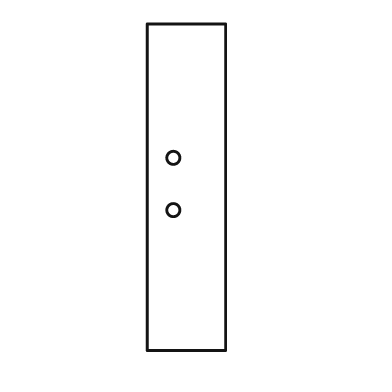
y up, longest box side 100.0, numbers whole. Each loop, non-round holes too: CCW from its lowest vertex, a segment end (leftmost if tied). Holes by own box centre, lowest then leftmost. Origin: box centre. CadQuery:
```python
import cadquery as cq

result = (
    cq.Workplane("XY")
    .moveTo(-12.0, -50.0)
    .lineTo(12.0, -50.0)
    .lineTo(12.0, 50.0)
    .lineTo(-12.0, 50.0)
    .close()
    .moveTo(-4.0, -7.0)
    .circle(2.0)
    .moveTo(-4.0, 9.0)
    .circle(2.0)
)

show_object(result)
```